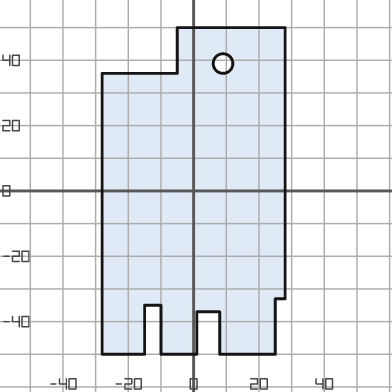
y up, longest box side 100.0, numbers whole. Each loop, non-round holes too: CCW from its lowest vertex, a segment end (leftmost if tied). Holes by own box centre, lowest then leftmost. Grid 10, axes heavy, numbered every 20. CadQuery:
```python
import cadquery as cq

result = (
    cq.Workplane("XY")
    .moveTo(-28.0, -50.0)
    .lineTo(-15.0, -50.0)
    .lineTo(-15.0, -35.0)
    .lineTo(-10.0, -35.0)
    .lineTo(-10.0, -50.0)
    .lineTo(1.0, -50.0)
    .lineTo(1.0, -37.0)
    .lineTo(8.0, -37.0)
    .lineTo(8.0, -50.0)
    .lineTo(25.0, -50.0)
    .lineTo(25.0, -33.0)
    .lineTo(28.0, -33.0)
    .lineTo(28.0, 50.0)
    .lineTo(-5.0, 50.0)
    .lineTo(-5.0, 36.0)
    .lineTo(-28.0, 36.0)
    .close()
    .moveTo(9.0, 39.0)
    .circle(3.0)
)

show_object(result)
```